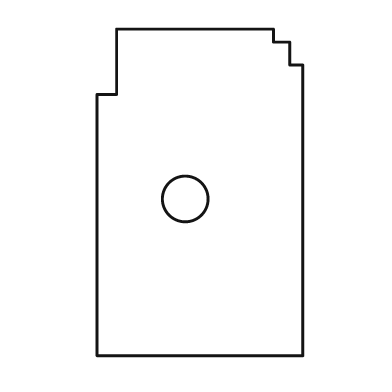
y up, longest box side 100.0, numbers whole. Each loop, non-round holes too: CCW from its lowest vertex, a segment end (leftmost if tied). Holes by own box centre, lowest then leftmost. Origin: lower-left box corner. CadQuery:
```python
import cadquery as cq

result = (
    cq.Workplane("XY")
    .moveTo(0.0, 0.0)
    .lineTo(63.0, 0.0)
    .lineTo(63.0, 89.0)
    .lineTo(59.0, 89.0)
    .lineTo(59.0, 96.0)
    .lineTo(54.0, 96.0)
    .lineTo(54.0, 100.0)
    .lineTo(6.0, 100.0)
    .lineTo(6.0, 80.0)
    .lineTo(0.0, 80.0)
    .close()
    .moveTo(27.0, 48.0)
    .circle(7.0)
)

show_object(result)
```